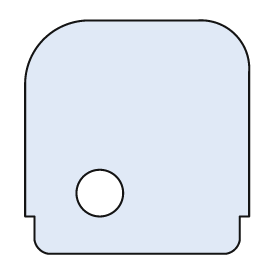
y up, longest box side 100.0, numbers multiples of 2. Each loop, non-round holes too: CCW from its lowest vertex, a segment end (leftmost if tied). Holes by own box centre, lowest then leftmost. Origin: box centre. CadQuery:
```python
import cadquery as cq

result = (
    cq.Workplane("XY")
    .moveTo(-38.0, -50.0)
    .lineTo(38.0, -50.0)
    .threePointArc((42.0, -48.0), (44.0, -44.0))
    .lineTo(44.0, -34.0)
    .lineTo(48.0, -34.0)
    .lineTo(48.0, 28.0)
    .threePointArc((42.0, 44.0), (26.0, 50.0))
    .lineTo(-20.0, 50.0)
    .threePointArc((-40.0, 42.0), (-48.0, 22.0))
    .lineTo(-48.0, -34.0)
    .lineTo(-44.0, -34.0)
    .lineTo(-44.0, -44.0)
    .threePointArc((-42.0, -48.0), (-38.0, -50.0))
    .close()
    .moveTo(-16.0, -24.0)
    .circle(10.0)
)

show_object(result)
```